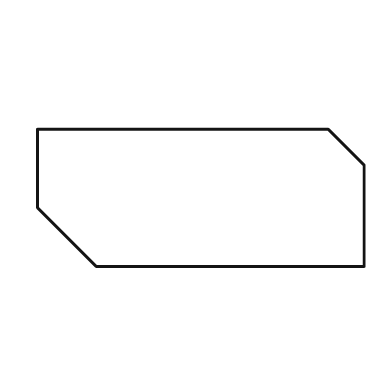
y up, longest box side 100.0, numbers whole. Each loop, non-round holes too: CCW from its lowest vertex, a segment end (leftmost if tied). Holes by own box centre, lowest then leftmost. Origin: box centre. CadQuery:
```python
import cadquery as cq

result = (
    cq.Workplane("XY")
    .moveTo(-32.0, -21.0)
    .lineTo(50.0, -21.0)
    .lineTo(50.0, 10.0)
    .lineTo(39.0, 21.0)
    .lineTo(-50.0, 21.0)
    .lineTo(-50.0, -3.0)
    .close()
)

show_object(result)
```